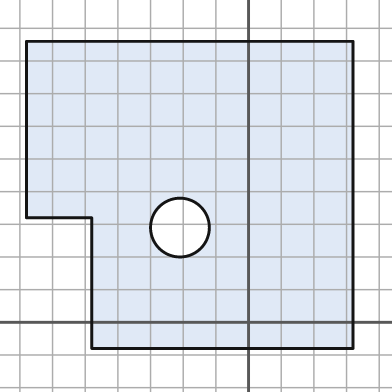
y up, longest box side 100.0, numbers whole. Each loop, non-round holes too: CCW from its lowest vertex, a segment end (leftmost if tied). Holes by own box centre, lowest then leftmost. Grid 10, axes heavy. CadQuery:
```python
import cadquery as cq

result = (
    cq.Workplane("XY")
    .moveTo(-48.0, -8.0)
    .lineTo(32.0, -8.0)
    .lineTo(32.0, 86.0)
    .lineTo(-68.0, 86.0)
    .lineTo(-68.0, 32.0)
    .lineTo(-48.0, 32.0)
    .close()
    .moveTo(-21.0, 29.0)
    .circle(9.0)
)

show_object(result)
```